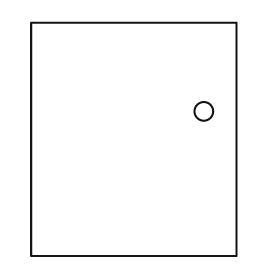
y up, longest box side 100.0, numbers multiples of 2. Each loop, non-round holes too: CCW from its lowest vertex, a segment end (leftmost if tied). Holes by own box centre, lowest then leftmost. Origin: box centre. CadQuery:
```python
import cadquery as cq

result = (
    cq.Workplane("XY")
    .moveTo(-44.0, -50.0)
    .lineTo(44.0, -50.0)
    .lineTo(44.0, 50.0)
    .lineTo(-44.0, 50.0)
    .close()
    .moveTo(30.0, 12.0)
    .circle(4.0)
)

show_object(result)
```